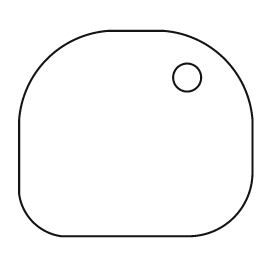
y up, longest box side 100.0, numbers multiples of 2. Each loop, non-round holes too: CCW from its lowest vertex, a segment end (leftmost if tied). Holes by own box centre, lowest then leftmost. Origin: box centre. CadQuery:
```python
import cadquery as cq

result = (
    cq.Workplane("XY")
    .moveTo(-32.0, -44.0)
    .lineTo(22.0, -44.0)
    .threePointArc((42.0, -36.0), (50.0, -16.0))
    .lineTo(50.0, 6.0)
    .threePointArc((38.0, 32.0), (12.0, 44.0))
    .lineTo(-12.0, 44.0)
    .threePointArc((-38.0, 32.0), (-50.0, 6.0))
    .lineTo(-50.0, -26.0)
    .threePointArc((-44.0, -38.0), (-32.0, -44.0))
    .close()
    .moveTo(22.0, 24.0)
    .circle(6.0)
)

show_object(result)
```